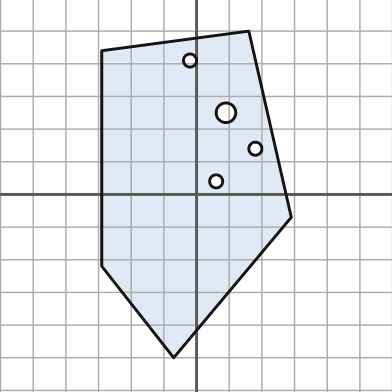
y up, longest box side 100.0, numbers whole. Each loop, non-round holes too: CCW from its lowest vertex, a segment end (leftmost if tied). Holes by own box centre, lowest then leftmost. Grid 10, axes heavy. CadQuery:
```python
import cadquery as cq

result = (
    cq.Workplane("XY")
    .moveTo(-7.0, -50.0)
    .lineTo(29.0, -7.0)
    .lineTo(16.0, 50.0)
    .lineTo(-29.0, 44.0)
    .lineTo(-29.0, -22.0)
    .close()
    .moveTo(6.0, 4.0)
    .circle(2.0)
    .moveTo(18.0, 14.0)
    .circle(2.0)
    .moveTo(9.0, 25.0)
    .circle(3.0)
    .moveTo(-2.0, 41.0)
    .circle(2.0)
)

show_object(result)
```